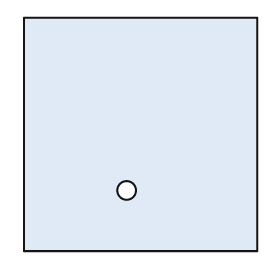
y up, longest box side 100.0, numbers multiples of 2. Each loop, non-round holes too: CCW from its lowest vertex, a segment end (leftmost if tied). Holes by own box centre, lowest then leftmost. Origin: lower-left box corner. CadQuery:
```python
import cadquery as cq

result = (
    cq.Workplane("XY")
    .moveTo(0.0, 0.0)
    .lineTo(100.0, 0.0)
    .lineTo(100.0, 100.0)
    .lineTo(0.0, 100.0)
    .close()
    .moveTo(44.0, 26.0)
    .circle(4.0)
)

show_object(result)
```